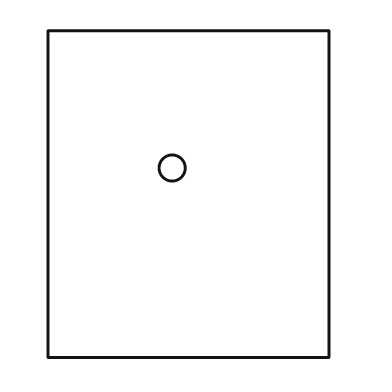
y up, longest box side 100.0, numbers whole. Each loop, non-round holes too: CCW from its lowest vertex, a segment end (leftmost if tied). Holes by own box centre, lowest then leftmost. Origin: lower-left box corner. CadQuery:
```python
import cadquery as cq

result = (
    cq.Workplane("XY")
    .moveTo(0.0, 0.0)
    .lineTo(86.0, 0.0)
    .lineTo(86.0, 100.0)
    .lineTo(0.0, 100.0)
    .close()
    .moveTo(38.0, 58.0)
    .circle(4.0)
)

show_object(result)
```